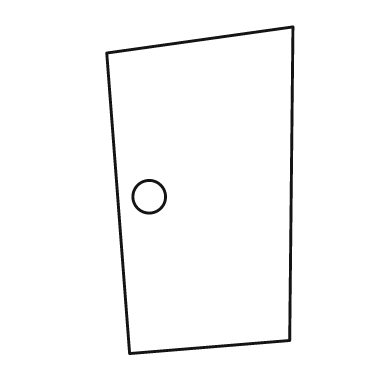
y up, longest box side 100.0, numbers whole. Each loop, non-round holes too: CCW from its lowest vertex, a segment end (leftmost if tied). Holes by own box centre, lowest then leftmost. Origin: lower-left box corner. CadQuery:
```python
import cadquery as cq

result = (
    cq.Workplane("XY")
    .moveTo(7.0, 0.0)
    .lineTo(56.0, 4.0)
    .lineTo(57.0, 100.0)
    .lineTo(0.0, 92.0)
    .close()
    .moveTo(13.0, 48.0)
    .circle(5.0)
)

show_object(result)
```